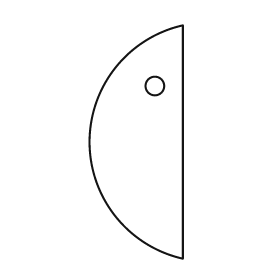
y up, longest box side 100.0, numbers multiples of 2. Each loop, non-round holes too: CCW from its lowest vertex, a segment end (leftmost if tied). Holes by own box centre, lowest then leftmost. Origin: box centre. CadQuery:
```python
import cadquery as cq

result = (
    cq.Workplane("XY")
    .moveTo(20.0, -50.0)
    .lineTo(20.0, 50.0)
    .threePointArc((-20.0, 0.0), (20.0, -50.0))
    .close()
    .moveTo(8.0, 24.0)
    .circle(4.0)
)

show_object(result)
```